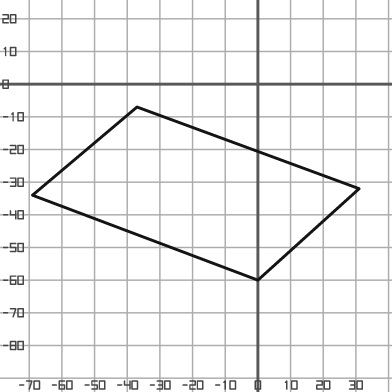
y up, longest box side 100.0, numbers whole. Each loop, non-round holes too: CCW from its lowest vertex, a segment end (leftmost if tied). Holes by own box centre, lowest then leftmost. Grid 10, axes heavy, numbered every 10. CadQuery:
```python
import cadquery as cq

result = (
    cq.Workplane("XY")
    .moveTo(0.0, -60.0)
    .lineTo(31.0, -32.0)
    .lineTo(-37.0, -7.0)
    .lineTo(-69.0, -34.0)
    .close()
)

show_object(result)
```